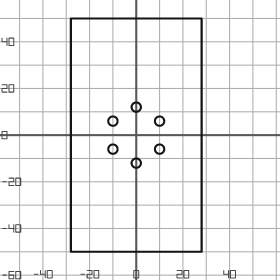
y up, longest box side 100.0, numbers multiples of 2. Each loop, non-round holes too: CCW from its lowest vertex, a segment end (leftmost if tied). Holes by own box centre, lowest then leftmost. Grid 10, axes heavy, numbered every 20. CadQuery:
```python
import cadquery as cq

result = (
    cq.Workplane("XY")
    .moveTo(-28.0, -50.0)
    .lineTo(28.0, -50.0)
    .lineTo(28.0, 50.0)
    .lineTo(-28.0, 50.0)
    .close()
    .moveTo(0.0, -12.0)
    .circle(2.0)
    .moveTo(-10.0, -6.0)
    .circle(2.0)
    .moveTo(10.0, -6.0)
    .circle(2.0)
    .moveTo(-10.0, 6.0)
    .circle(2.0)
    .moveTo(10.0, 6.0)
    .circle(2.0)
    .moveTo(0.0, 12.0)
    .circle(2.0)
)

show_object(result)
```